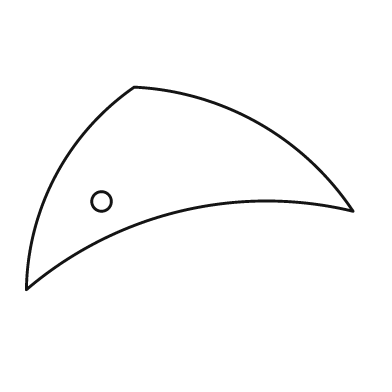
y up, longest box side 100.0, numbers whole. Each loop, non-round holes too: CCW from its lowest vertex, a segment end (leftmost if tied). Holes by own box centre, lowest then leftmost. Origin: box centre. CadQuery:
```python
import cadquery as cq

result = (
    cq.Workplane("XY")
    .moveTo(-50.0, -31.0)
    .threePointArc((-3.0, -7.0), (50.0, -7.0))
    .threePointArc((21.0, 20.0), (-17.0, 31.0))
    .threePointArc((-41.0, 4.0), (-50.0, -31.0))
    .close()
    .moveTo(-27.0, -4.0)
    .circle(3.0)
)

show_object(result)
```